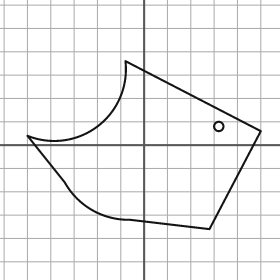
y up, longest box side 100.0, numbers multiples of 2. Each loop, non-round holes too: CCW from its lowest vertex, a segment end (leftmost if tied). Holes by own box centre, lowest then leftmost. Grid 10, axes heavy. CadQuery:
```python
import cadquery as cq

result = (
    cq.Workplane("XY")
    .moveTo(28.0, -36.0)
    .lineTo(50.0, 6.0)
    .lineTo(-8.0, 36.0)
    .threePointArc((-20.0, 8.0), (-50.0, 4.0))
    .lineTo(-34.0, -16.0)
    .threePointArc((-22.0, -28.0), (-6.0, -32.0))
    .close()
    .moveTo(32.0, 8.0)
    .circle(2.0)
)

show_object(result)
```